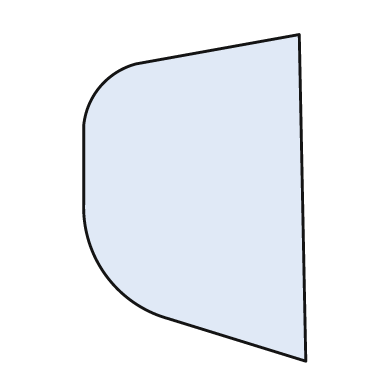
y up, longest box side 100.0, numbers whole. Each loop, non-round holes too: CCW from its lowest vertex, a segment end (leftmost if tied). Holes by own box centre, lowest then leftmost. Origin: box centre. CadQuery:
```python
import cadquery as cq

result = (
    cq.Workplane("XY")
    .moveTo(34.0, -50.0)
    .lineTo(32.0, 50.0)
    .lineTo(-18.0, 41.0)
    .threePointArc((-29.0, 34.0), (-34.0, 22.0))
    .lineTo(-34.0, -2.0)
    .threePointArc((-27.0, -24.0), (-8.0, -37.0))
    .close()
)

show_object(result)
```